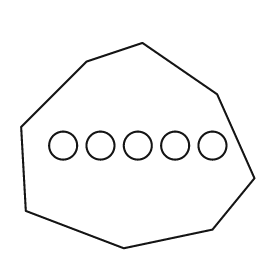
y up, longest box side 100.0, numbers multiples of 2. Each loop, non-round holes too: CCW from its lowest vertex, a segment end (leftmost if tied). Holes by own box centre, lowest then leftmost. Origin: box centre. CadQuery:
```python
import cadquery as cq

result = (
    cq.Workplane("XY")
    .moveTo(-6.0, -44.0)
    .lineTo(32.0, -36.0)
    .lineTo(50.0, -14.0)
    .lineTo(34.0, 22.0)
    .lineTo(2.0, 44.0)
    .lineTo(-22.0, 36.0)
    .lineTo(-50.0, 8.0)
    .lineTo(-48.0, -28.0)
    .close()
    .moveTo(-32.0, 0.0)
    .circle(6.0)
    .moveTo(-16.0, 0.0)
    .circle(6.0)
    .moveTo(0.0, 0.0)
    .circle(6.0)
    .moveTo(16.0, 0.0)
    .circle(6.0)
    .moveTo(32.0, 0.0)
    .circle(6.0)
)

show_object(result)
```